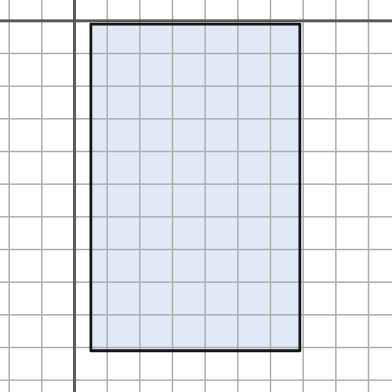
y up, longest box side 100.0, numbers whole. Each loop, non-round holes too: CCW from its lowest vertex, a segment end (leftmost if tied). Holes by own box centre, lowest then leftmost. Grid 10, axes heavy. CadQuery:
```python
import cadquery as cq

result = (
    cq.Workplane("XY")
    .moveTo(5.0, -101.0)
    .lineTo(69.0, -101.0)
    .lineTo(69.0, -1.0)
    .lineTo(5.0, -1.0)
    .close()
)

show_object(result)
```